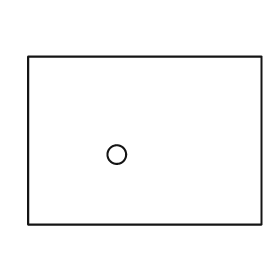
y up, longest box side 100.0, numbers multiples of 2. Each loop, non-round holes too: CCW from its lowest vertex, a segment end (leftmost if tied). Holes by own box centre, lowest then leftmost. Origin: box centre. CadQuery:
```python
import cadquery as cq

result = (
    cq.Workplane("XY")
    .moveTo(-50.0, -36.0)
    .lineTo(50.0, -36.0)
    .lineTo(50.0, 36.0)
    .lineTo(-50.0, 36.0)
    .close()
    .moveTo(-12.0, -6.0)
    .circle(4.0)
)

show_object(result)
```